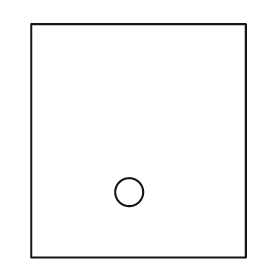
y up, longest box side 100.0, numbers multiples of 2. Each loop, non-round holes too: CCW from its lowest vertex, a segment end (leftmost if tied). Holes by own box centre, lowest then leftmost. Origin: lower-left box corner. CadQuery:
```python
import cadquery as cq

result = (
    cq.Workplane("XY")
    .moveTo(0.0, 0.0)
    .lineTo(92.0, 0.0)
    .lineTo(92.0, 100.0)
    .lineTo(0.0, 100.0)
    .close()
    .moveTo(42.0, 28.0)
    .circle(6.0)
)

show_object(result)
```